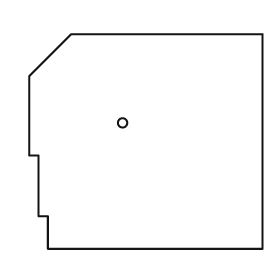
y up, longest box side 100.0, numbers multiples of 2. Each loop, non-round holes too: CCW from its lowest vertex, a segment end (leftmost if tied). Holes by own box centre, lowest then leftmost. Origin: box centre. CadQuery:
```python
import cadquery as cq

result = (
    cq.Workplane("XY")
    .moveTo(-42.0, -46.0)
    .lineTo(50.0, -46.0)
    .lineTo(50.0, 46.0)
    .lineTo(-32.0, 46.0)
    .lineTo(-50.0, 28.0)
    .lineTo(-50.0, -6.0)
    .lineTo(-46.0, -6.0)
    .lineTo(-46.0, -32.0)
    .lineTo(-42.0, -32.0)
    .close()
    .moveTo(-10.0, 8.0)
    .circle(2.0)
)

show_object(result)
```